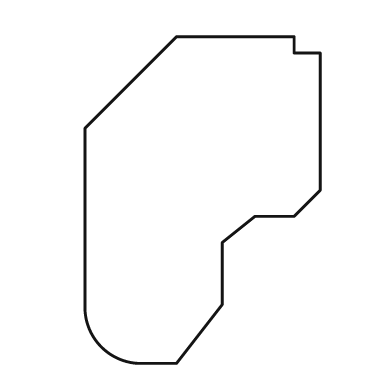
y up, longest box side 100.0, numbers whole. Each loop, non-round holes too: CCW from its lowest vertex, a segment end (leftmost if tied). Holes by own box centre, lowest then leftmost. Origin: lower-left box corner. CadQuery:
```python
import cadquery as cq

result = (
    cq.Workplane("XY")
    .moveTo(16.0, 0.0)
    .lineTo(28.0, 0.0)
    .lineTo(42.0, 18.0)
    .lineTo(42.0, 37.0)
    .lineTo(52.0, 45.0)
    .lineTo(64.0, 45.0)
    .lineTo(72.0, 53.0)
    .lineTo(72.0, 95.0)
    .lineTo(64.0, 95.0)
    .lineTo(64.0, 100.0)
    .lineTo(28.0, 100.0)
    .lineTo(0.0, 72.0)
    .lineTo(0.0, 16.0)
    .threePointArc((5.0, 5.0), (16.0, 0.0))
    .close()
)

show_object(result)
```